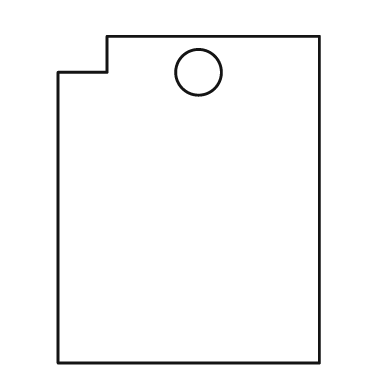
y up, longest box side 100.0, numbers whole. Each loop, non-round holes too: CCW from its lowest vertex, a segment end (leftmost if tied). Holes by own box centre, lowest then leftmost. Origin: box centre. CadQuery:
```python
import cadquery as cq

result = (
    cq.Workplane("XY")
    .moveTo(-40.0, -50.0)
    .lineTo(40.0, -50.0)
    .lineTo(40.0, 50.0)
    .lineTo(-25.0, 50.0)
    .lineTo(-25.0, 39.0)
    .lineTo(-40.0, 39.0)
    .close()
    .moveTo(3.0, 39.0)
    .circle(7.0)
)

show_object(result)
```